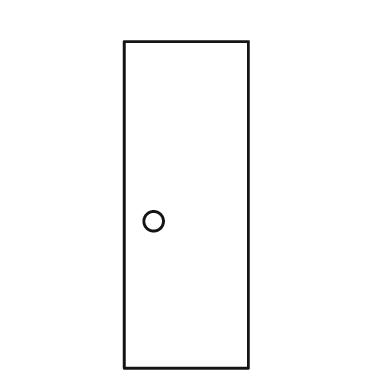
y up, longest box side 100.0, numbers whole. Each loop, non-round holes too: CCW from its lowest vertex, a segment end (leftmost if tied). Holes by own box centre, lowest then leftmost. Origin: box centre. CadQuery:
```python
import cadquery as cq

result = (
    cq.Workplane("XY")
    .moveTo(-19.0, -50.0)
    .lineTo(19.0, -50.0)
    .lineTo(19.0, 50.0)
    .lineTo(-19.0, 50.0)
    .close()
    .moveTo(-10.0, -5.0)
    .circle(3.0)
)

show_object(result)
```